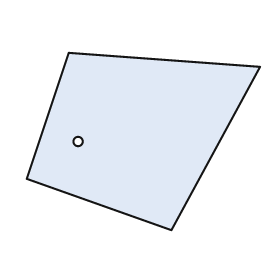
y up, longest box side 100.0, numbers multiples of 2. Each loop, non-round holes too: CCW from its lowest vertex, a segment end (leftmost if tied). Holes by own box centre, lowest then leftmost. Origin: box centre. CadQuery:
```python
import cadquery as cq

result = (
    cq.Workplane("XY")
    .moveTo(12.0, -38.0)
    .lineTo(50.0, 32.0)
    .lineTo(-32.0, 38.0)
    .lineTo(-50.0, -16.0)
    .close()
    .moveTo(-28.0, 0.0)
    .circle(2.0)
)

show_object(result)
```